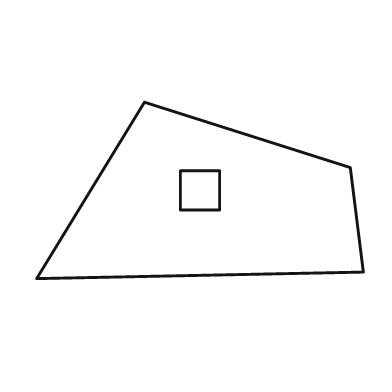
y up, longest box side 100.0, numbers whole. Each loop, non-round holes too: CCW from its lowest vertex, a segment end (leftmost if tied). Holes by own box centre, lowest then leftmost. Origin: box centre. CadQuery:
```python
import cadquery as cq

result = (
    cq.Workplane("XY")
    .moveTo(-50.0, -27.0)
    .lineTo(50.0, -25.0)
    .lineTo(46.0, 7.0)
    .lineTo(-17.0, 27.0)
    .close()
    .moveTo(-6.0, -6.0)
    .lineTo(6.0, -6.0)
    .lineTo(6.0, 6.0)
    .lineTo(-6.0, 6.0)
    .close()
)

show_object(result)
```